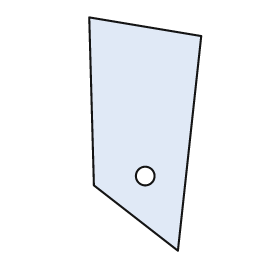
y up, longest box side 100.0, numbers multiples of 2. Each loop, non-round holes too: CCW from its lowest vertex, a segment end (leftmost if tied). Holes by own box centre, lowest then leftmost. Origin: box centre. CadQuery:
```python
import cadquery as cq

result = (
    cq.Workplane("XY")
    .moveTo(14.0, -50.0)
    .lineTo(24.0, 42.0)
    .lineTo(-24.0, 50.0)
    .lineTo(-22.0, -22.0)
    .close()
    .moveTo(0.0, -18.0)
    .circle(4.0)
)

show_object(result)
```